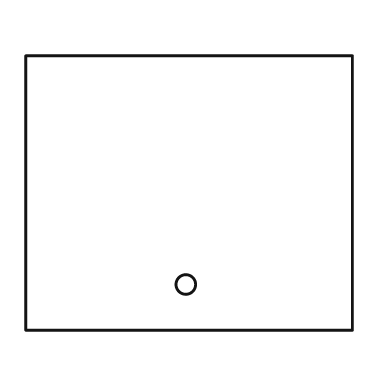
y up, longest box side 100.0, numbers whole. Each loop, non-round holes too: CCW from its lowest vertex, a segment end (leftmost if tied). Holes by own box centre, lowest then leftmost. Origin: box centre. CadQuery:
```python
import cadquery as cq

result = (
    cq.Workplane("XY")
    .moveTo(-50.0, -42.0)
    .lineTo(50.0, -42.0)
    .lineTo(50.0, 42.0)
    .lineTo(-50.0, 42.0)
    .close()
    .moveTo(-1.0, -28.0)
    .circle(3.0)
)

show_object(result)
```